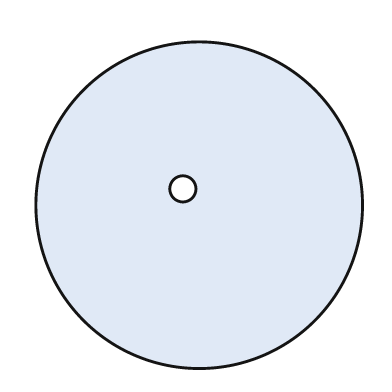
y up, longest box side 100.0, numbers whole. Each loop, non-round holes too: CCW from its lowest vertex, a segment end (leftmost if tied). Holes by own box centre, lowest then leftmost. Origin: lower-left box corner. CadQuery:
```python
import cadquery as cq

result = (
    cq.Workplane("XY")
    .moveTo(50.0, 50.0)
    .circle(50.0)
    .moveTo(45.0, 55.0)
    .circle(4.0)
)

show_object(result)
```